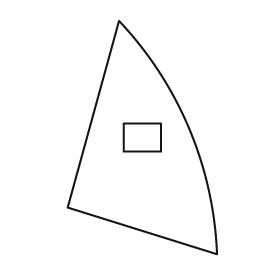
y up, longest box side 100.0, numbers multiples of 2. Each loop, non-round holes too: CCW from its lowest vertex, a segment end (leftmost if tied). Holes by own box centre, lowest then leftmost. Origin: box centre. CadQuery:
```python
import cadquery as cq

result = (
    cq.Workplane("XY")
    .moveTo(32.0, -50.0)
    .threePointArc((20.0, 4.0), (-10.0, 50.0))
    .lineTo(-32.0, -30.0)
    .close()
    .moveTo(-8.0, -6.0)
    .lineTo(8.0, -6.0)
    .lineTo(8.0, 6.0)
    .lineTo(-8.0, 6.0)
    .close()
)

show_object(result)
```